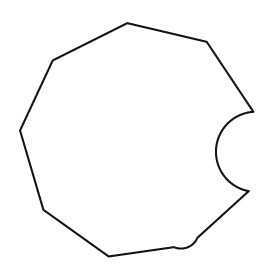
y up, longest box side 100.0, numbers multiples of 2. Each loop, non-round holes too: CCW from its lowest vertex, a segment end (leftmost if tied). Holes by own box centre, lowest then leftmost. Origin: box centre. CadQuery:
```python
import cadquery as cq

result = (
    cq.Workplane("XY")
    .moveTo(-12.0, -50.0)
    .lineTo(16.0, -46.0)
    .threePointArc((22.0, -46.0), (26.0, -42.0))
    .lineTo(48.0, -22.0)
    .threePointArc((34.0, -4.0), (50.0, 12.0))
    .lineTo(30.0, 42.0)
    .lineTo(-4.0, 50.0)
    .lineTo(-36.0, 34.0)
    .lineTo(-50.0, 4.0)
    .lineTo(-40.0, -30.0)
    .close()
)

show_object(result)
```